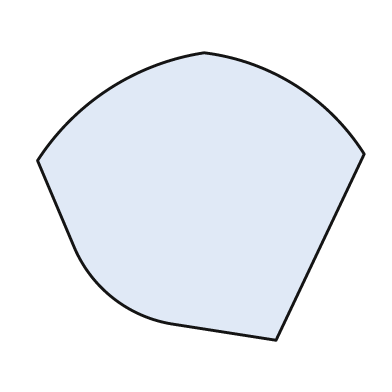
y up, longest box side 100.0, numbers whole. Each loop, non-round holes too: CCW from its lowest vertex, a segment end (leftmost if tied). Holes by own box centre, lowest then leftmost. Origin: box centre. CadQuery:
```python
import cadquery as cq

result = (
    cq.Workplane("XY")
    .moveTo(23.0, -44.0)
    .lineTo(50.0, 13.0)
    .threePointArc((29.0, 34.0), (1.0, 44.0))
    .threePointArc((-28.0, 33.0), (-50.0, 11.0))
    .lineTo(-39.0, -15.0)
    .threePointArc((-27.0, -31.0), (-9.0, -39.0))
    .close()
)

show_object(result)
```